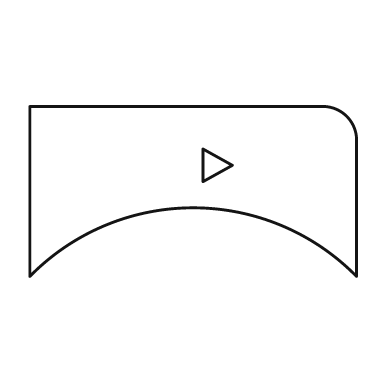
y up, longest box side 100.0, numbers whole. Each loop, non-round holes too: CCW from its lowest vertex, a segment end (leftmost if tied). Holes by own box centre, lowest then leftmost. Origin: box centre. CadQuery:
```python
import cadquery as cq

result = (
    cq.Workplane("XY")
    .moveTo(-50.0, -26.0)
    .threePointArc((0.0, -5.0), (50.0, -26.0))
    .lineTo(50.0, 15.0)
    .threePointArc((47.0, 23.0), (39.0, 26.0))
    .lineTo(-50.0, 26.0)
    .close()
    .moveTo(3.0, 3.0)
    .lineTo(12.0, 8.0)
    .lineTo(3.0, 13.0)
    .close()
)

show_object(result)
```